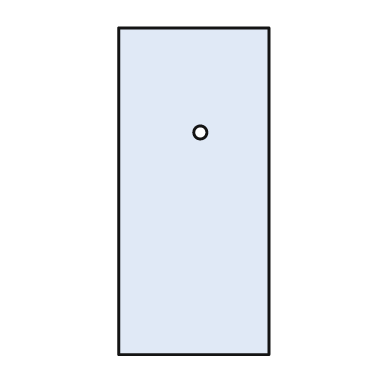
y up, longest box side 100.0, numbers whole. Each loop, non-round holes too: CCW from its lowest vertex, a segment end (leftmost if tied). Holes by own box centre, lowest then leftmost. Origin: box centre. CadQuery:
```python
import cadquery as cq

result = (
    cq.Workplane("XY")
    .moveTo(-23.0, -50.0)
    .lineTo(23.0, -50.0)
    .lineTo(23.0, 50.0)
    .lineTo(-23.0, 50.0)
    .close()
    .moveTo(2.0, 18.0)
    .circle(2.0)
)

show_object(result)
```